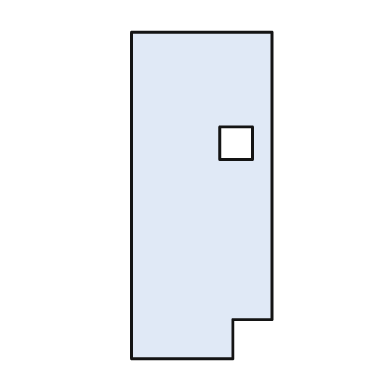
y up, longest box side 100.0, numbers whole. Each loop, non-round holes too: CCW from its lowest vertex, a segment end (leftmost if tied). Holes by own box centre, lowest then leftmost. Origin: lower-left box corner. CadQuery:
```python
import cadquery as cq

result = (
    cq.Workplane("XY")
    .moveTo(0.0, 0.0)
    .lineTo(31.0, 0.0)
    .lineTo(31.0, 12.0)
    .lineTo(43.0, 12.0)
    .lineTo(43.0, 100.0)
    .lineTo(0.0, 100.0)
    .close()
    .moveTo(27.0, 61.0)
    .lineTo(37.0, 61.0)
    .lineTo(37.0, 71.0)
    .lineTo(27.0, 71.0)
    .close()
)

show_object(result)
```